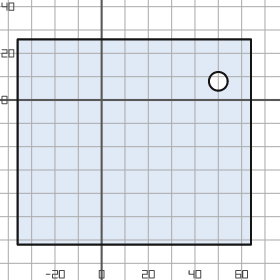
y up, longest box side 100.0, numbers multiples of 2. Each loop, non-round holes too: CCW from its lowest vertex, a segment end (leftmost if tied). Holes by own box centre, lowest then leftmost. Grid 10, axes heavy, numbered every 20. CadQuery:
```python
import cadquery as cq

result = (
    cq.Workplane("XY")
    .moveTo(-36.0, -62.0)
    .lineTo(64.0, -62.0)
    .lineTo(64.0, 26.0)
    .lineTo(-36.0, 26.0)
    .close()
    .moveTo(50.0, 8.0)
    .circle(4.0)
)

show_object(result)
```